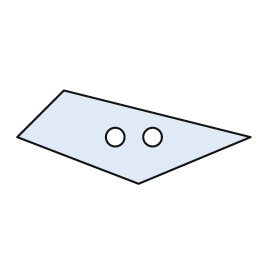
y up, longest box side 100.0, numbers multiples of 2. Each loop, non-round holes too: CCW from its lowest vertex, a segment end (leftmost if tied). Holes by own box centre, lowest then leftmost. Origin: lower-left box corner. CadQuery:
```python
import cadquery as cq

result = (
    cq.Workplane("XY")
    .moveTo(52.0, 0.0)
    .lineTo(100.0, 20.0)
    .lineTo(20.0, 40.0)
    .lineTo(0.0, 20.0)
    .close()
    .moveTo(42.0, 20.0)
    .circle(4.0)
    .moveTo(58.0, 20.0)
    .circle(4.0)
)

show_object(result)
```